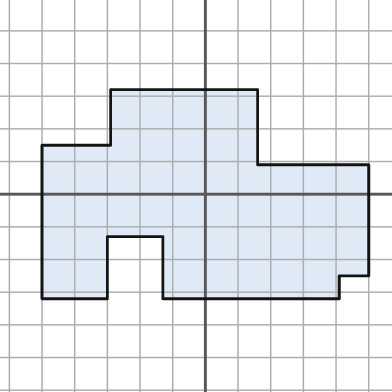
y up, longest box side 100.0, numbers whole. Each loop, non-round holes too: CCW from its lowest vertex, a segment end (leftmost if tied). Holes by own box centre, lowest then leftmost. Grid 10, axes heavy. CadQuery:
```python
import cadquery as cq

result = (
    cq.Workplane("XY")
    .moveTo(-50.0, -32.0)
    .lineTo(-30.0, -32.0)
    .lineTo(-30.0, -13.0)
    .lineTo(-13.0, -13.0)
    .lineTo(-13.0, -32.0)
    .lineTo(41.0, -32.0)
    .lineTo(41.0, -25.0)
    .lineTo(50.0, -25.0)
    .lineTo(50.0, 9.0)
    .lineTo(16.0, 9.0)
    .lineTo(16.0, 32.0)
    .lineTo(-29.0, 32.0)
    .lineTo(-29.0, 15.0)
    .lineTo(-50.0, 15.0)
    .close()
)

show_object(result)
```